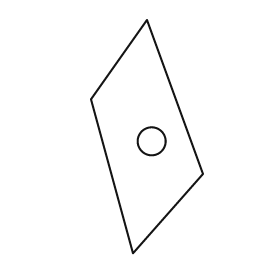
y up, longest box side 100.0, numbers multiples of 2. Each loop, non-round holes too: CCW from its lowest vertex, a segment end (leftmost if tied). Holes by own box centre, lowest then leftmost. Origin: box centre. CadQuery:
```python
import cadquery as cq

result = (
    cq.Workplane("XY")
    .moveTo(-6.0, -50.0)
    .lineTo(24.0, -16.0)
    .lineTo(0.0, 50.0)
    .lineTo(-24.0, 16.0)
    .close()
    .moveTo(2.0, -2.0)
    .circle(6.0)
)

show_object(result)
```